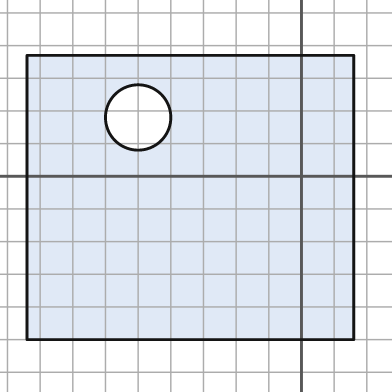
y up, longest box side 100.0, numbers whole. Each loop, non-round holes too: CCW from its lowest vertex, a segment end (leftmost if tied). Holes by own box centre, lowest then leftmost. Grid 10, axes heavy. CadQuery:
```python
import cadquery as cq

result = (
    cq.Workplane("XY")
    .moveTo(-84.0, -50.0)
    .lineTo(16.0, -50.0)
    .lineTo(16.0, 37.0)
    .lineTo(-84.0, 37.0)
    .close()
    .moveTo(-50.0, 18.0)
    .circle(10.0)
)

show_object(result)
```